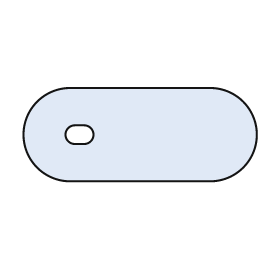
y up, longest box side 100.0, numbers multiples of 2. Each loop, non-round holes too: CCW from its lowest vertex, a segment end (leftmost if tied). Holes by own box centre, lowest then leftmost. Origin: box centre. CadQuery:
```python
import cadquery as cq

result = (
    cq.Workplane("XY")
    .moveTo(-30.0, -20.0)
    .lineTo(30.0, -20.0)
    .threePointArc((50.0, 0.0), (30.0, 20.0))
    .lineTo(-30.0, 20.0)
    .threePointArc((-50.0, 0.0), (-30.0, -20.0))
    .close()
    .moveTo(-28.0, -4.0)
    .lineTo(-24.0, -4.0)
    .threePointArc((-20.0, 0.0), (-24.0, 4.0))
    .lineTo(-28.0, 4.0)
    .threePointArc((-32.0, 0.0), (-28.0, -4.0))
    .close()
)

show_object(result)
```